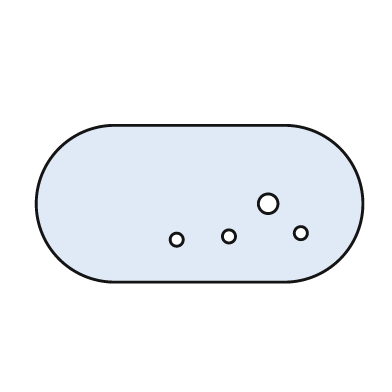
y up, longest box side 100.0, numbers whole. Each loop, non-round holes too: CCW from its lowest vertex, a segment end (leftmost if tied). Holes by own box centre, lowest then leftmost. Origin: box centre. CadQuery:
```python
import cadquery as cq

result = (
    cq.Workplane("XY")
    .moveTo(-26.0, -24.0)
    .lineTo(26.0, -24.0)
    .threePointArc((50.0, 0.0), (26.0, 24.0))
    .lineTo(-26.0, 24.0)
    .threePointArc((-50.0, 0.0), (-26.0, -24.0))
    .close()
    .moveTo(-7.0, -11.0)
    .circle(2.0)
    .moveTo(9.0, -10.0)
    .circle(2.0)
    .moveTo(31.0, -9.0)
    .circle(2.0)
    .moveTo(21.0, 0.0)
    .circle(3.0)
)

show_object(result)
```